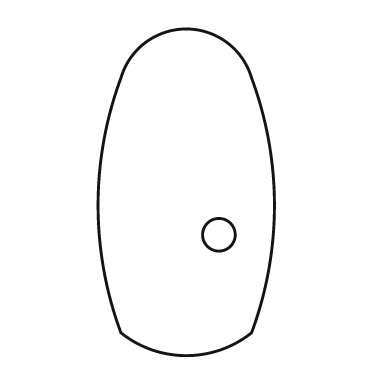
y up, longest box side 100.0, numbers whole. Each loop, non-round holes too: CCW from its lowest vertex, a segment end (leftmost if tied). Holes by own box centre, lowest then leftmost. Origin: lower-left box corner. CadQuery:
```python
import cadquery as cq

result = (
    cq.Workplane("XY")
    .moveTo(7.0, 7.0)
    .threePointArc((27.0, 0.0), (47.0, 7.0))
    .threePointArc((54.0, 46.0), (47.0, 85.0))
    .threePointArc((27.0, 100.0), (7.0, 85.0))
    .threePointArc((0.0, 46.0), (7.0, 7.0))
    .close()
    .moveTo(37.0, 37.0)
    .circle(5.0)
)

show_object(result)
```